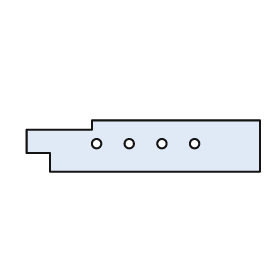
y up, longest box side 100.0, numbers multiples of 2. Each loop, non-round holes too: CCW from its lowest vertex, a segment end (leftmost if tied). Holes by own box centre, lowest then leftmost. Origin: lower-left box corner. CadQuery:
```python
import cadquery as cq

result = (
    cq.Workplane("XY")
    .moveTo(10.0, 0.0)
    .lineTo(100.0, 0.0)
    .lineTo(100.0, 22.0)
    .lineTo(28.0, 22.0)
    .lineTo(28.0, 18.0)
    .lineTo(0.0, 18.0)
    .lineTo(0.0, 8.0)
    .lineTo(10.0, 8.0)
    .close()
    .moveTo(30.0, 12.0)
    .circle(2.0)
    .moveTo(44.0, 12.0)
    .circle(2.0)
    .moveTo(58.0, 12.0)
    .circle(2.0)
    .moveTo(72.0, 12.0)
    .circle(2.0)
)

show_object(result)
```